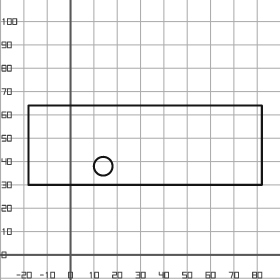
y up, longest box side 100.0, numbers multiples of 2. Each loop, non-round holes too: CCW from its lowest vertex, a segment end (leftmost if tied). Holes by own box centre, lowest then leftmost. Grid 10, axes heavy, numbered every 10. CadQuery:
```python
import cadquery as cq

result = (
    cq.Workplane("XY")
    .moveTo(-18.0, 30.0)
    .lineTo(82.0, 30.0)
    .lineTo(82.0, 64.0)
    .lineTo(-18.0, 64.0)
    .close()
    .moveTo(14.0, 38.0)
    .circle(4.0)
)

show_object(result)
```